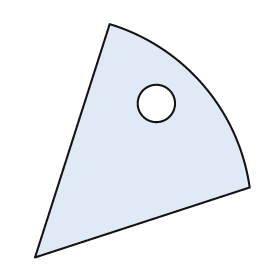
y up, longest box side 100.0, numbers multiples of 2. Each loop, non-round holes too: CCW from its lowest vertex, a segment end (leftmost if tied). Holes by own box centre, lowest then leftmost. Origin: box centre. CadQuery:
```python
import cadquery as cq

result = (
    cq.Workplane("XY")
    .moveTo(-46.0, -50.0)
    .lineTo(46.0, -20.0)
    .threePointArc((26.0, 24.0), (-14.0, 50.0))
    .close()
    .moveTo(6.0, 16.0)
    .circle(8.0)
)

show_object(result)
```